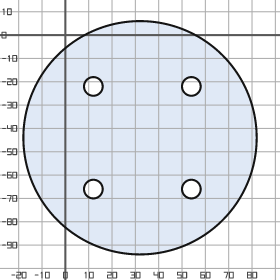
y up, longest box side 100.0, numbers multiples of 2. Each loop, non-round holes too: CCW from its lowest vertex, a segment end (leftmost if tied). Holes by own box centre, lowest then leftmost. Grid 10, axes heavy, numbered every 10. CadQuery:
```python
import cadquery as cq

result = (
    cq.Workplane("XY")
    .moveTo(32.0, -44.0)
    .circle(50.0)
    .moveTo(12.0, -66.0)
    .circle(4.0)
    .moveTo(54.0, -66.0)
    .circle(4.0)
    .moveTo(12.0, -22.0)
    .circle(4.0)
    .moveTo(54.0, -22.0)
    .circle(4.0)
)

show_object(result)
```